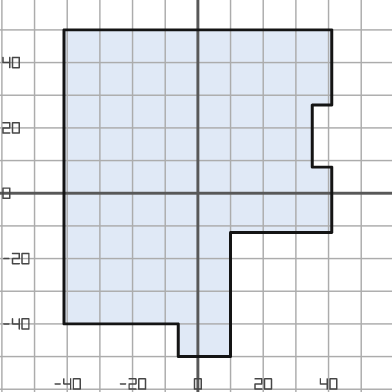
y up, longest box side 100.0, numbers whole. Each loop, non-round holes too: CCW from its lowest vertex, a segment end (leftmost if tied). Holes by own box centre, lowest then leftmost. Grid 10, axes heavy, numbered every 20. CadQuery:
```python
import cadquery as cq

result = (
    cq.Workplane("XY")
    .moveTo(-6.0, -50.0)
    .lineTo(10.0, -50.0)
    .lineTo(10.0, -12.0)
    .lineTo(41.0, -12.0)
    .lineTo(41.0, 8.0)
    .lineTo(35.0, 8.0)
    .lineTo(35.0, 27.0)
    .lineTo(41.0, 27.0)
    .lineTo(41.0, 50.0)
    .lineTo(-41.0, 50.0)
    .lineTo(-41.0, -40.0)
    .lineTo(-6.0, -40.0)
    .close()
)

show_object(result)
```